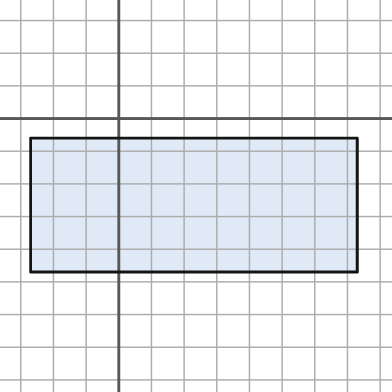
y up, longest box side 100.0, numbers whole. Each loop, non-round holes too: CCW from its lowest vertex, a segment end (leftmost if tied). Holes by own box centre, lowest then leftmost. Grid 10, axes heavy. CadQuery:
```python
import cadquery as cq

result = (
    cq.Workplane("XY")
    .moveTo(-27.0, -47.0)
    .lineTo(73.0, -47.0)
    .lineTo(73.0, -6.0)
    .lineTo(-27.0, -6.0)
    .close()
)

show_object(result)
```